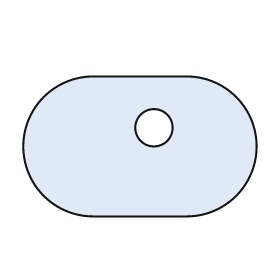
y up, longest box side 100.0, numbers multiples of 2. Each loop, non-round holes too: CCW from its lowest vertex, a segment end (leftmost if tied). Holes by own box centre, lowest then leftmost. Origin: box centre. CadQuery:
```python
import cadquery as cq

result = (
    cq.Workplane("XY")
    .moveTo(-20.0, -30.0)
    .lineTo(20.0, -30.0)
    .threePointArc((50.0, 0.0), (20.0, 30.0))
    .lineTo(-20.0, 30.0)
    .threePointArc((-50.0, 0.0), (-20.0, -30.0))
    .close()
    .moveTo(6.0, 8.0)
    .circle(8.0)
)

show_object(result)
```